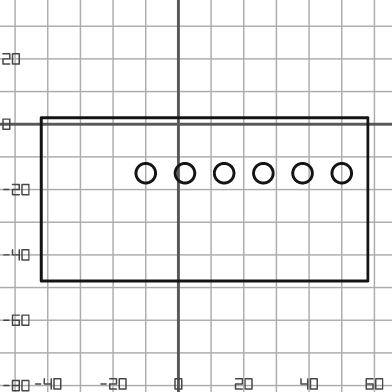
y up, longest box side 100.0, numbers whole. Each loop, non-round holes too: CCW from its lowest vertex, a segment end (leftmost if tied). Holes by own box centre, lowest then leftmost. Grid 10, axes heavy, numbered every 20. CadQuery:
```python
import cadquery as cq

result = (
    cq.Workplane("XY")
    .moveTo(-42.0, -48.0)
    .lineTo(58.0, -48.0)
    .lineTo(58.0, 2.0)
    .lineTo(-42.0, 2.0)
    .close()
    .moveTo(-10.0, -15.0)
    .circle(3.0)
    .moveTo(2.0, -15.0)
    .circle(3.0)
    .moveTo(14.0, -15.0)
    .circle(3.0)
    .moveTo(26.0, -15.0)
    .circle(3.0)
    .moveTo(38.0, -15.0)
    .circle(3.0)
    .moveTo(50.0, -15.0)
    .circle(3.0)
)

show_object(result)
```